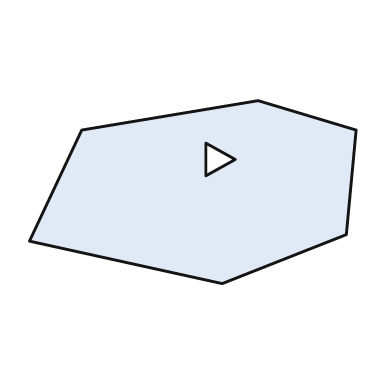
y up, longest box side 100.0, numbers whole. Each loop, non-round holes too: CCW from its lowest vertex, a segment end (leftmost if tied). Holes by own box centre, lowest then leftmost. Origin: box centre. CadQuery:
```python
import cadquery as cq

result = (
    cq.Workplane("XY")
    .moveTo(9.0, -28.0)
    .lineTo(47.0, -13.0)
    .lineTo(50.0, 19.0)
    .lineTo(20.0, 28.0)
    .lineTo(-34.0, 19.0)
    .lineTo(-50.0, -15.0)
    .close()
    .moveTo(4.0, 5.0)
    .lineTo(13.0, 10.0)
    .lineTo(4.0, 15.0)
    .close()
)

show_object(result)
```